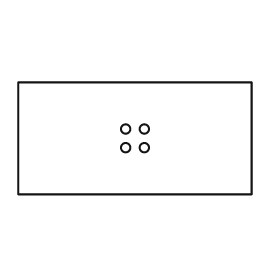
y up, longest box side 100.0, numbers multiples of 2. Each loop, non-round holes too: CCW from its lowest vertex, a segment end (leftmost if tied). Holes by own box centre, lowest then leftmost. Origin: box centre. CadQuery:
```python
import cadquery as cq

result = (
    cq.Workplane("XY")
    .moveTo(-50.0, -24.0)
    .lineTo(50.0, -24.0)
    .lineTo(50.0, 24.0)
    .lineTo(-50.0, 24.0)
    .close()
    .moveTo(-4.0, -4.0)
    .circle(2.0)
    .moveTo(4.0, -4.0)
    .circle(2.0)
    .moveTo(-4.0, 4.0)
    .circle(2.0)
    .moveTo(4.0, 4.0)
    .circle(2.0)
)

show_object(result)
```